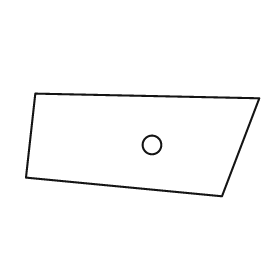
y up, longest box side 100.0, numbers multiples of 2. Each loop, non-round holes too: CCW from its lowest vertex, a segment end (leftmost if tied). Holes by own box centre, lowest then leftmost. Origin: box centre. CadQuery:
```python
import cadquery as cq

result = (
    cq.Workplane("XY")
    .moveTo(34.0, -22.0)
    .lineTo(50.0, 20.0)
    .lineTo(-46.0, 22.0)
    .lineTo(-50.0, -14.0)
    .close()
    .moveTo(4.0, 0.0)
    .circle(4.0)
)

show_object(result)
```